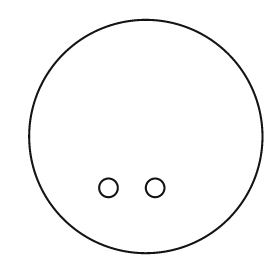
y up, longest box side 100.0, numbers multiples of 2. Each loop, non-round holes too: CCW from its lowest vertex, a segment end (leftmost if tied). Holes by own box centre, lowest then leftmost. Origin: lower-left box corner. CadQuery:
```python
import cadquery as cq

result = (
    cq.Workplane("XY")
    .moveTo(50.0, 50.0)
    .circle(50.0)
    .moveTo(34.0, 28.0)
    .circle(4.0)
    .moveTo(54.0, 28.0)
    .circle(4.0)
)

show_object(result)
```